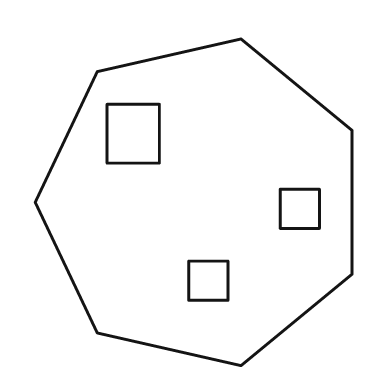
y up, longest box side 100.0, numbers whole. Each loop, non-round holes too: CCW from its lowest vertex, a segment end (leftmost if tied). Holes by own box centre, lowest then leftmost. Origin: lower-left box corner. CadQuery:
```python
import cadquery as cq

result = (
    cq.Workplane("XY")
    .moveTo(63.0, 0.0)
    .lineTo(97.0, 28.0)
    .lineTo(97.0, 72.0)
    .lineTo(63.0, 100.0)
    .lineTo(19.0, 90.0)
    .lineTo(0.0, 50.0)
    .lineTo(19.0, 10.0)
    .close()
    .moveTo(47.0, 20.0)
    .lineTo(59.0, 20.0)
    .lineTo(59.0, 32.0)
    .lineTo(47.0, 32.0)
    .close()
    .moveTo(75.0, 42.0)
    .lineTo(87.0, 42.0)
    .lineTo(87.0, 54.0)
    .lineTo(75.0, 54.0)
    .close()
    .moveTo(22.0, 62.0)
    .lineTo(38.0, 62.0)
    .lineTo(38.0, 80.0)
    .lineTo(22.0, 80.0)
    .close()
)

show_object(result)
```